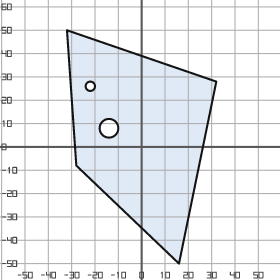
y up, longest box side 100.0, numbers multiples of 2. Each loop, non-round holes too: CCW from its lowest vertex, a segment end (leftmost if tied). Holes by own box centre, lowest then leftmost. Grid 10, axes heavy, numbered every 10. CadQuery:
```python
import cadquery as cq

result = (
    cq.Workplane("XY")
    .moveTo(16.0, -50.0)
    .lineTo(32.0, 28.0)
    .lineTo(-32.0, 50.0)
    .lineTo(-28.0, -8.0)
    .close()
    .moveTo(-14.0, 8.0)
    .circle(4.0)
    .moveTo(-22.0, 26.0)
    .circle(2.0)
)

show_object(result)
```